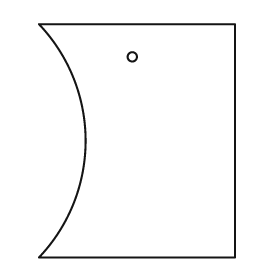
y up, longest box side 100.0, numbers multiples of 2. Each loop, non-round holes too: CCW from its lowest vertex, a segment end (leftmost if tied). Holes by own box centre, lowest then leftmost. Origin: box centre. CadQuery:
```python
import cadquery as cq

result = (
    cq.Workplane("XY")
    .moveTo(-42.0, -50.0)
    .lineTo(42.0, -50.0)
    .lineTo(42.0, 50.0)
    .lineTo(-42.0, 50.0)
    .threePointArc((-22.0, 0.0), (-42.0, -50.0))
    .close()
    .moveTo(-2.0, 36.0)
    .circle(2.0)
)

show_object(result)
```